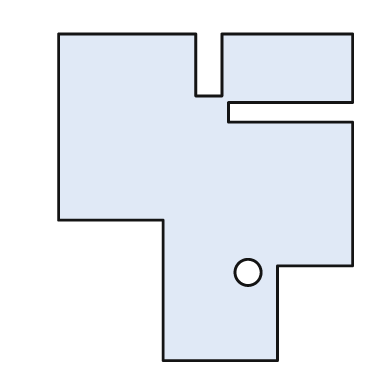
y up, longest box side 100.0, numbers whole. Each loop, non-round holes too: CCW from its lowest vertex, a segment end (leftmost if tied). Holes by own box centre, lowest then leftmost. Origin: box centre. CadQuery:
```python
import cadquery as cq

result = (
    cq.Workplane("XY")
    .moveTo(-13.0, -50.0)
    .lineTo(22.0, -50.0)
    .lineTo(22.0, -21.0)
    .lineTo(45.0, -21.0)
    .lineTo(45.0, 23.0)
    .lineTo(7.0, 23.0)
    .lineTo(7.0, 29.0)
    .lineTo(45.0, 29.0)
    .lineTo(45.0, 50.0)
    .lineTo(5.0, 50.0)
    .lineTo(5.0, 31.0)
    .lineTo(-3.0, 31.0)
    .lineTo(-3.0, 50.0)
    .lineTo(-45.0, 50.0)
    .lineTo(-45.0, -7.0)
    .lineTo(-13.0, -7.0)
    .close()
    .moveTo(13.0, -23.0)
    .circle(4.0)
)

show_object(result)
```